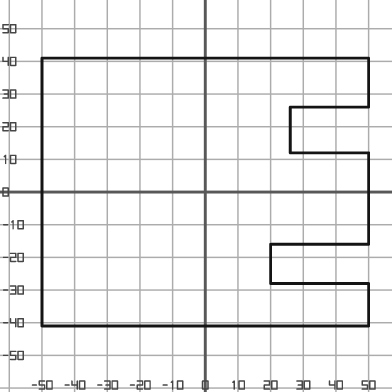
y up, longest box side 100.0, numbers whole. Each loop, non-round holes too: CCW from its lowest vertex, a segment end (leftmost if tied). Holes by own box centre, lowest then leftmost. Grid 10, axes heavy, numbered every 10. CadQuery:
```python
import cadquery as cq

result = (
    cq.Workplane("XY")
    .moveTo(-50.0, -41.0)
    .lineTo(50.0, -41.0)
    .lineTo(50.0, -28.0)
    .lineTo(20.0, -28.0)
    .lineTo(20.0, -16.0)
    .lineTo(50.0, -16.0)
    .lineTo(50.0, 12.0)
    .lineTo(26.0, 12.0)
    .lineTo(26.0, 26.0)
    .lineTo(50.0, 26.0)
    .lineTo(50.0, 41.0)
    .lineTo(-50.0, 41.0)
    .close()
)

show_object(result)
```